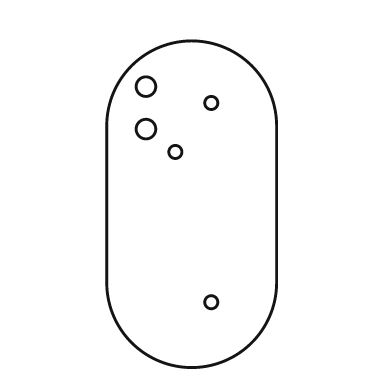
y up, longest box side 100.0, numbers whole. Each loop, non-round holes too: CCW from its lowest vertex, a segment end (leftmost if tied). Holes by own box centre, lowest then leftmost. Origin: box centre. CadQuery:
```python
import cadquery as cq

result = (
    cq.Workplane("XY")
    .moveTo(-26.0, -24.0)
    .threePointArc((0.0, -50.0), (26.0, -24.0))
    .lineTo(26.0, 24.0)
    .threePointArc((0.0, 50.0), (-26.0, 24.0))
    .close()
    .moveTo(6.0, -30.0)
    .circle(2.0)
    .moveTo(-5.0, 16.0)
    .circle(2.0)
    .moveTo(-14.0, 23.0)
    .circle(3.0)
    .moveTo(6.0, 31.0)
    .circle(2.0)
    .moveTo(-14.0, 36.0)
    .circle(3.0)
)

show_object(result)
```